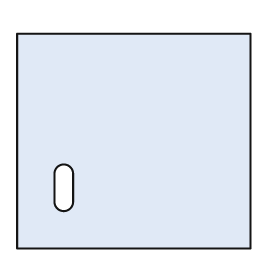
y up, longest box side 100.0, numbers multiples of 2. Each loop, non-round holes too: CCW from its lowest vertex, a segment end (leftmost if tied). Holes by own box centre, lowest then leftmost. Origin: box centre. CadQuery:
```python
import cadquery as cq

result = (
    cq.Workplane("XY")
    .moveTo(-50.0, -46.0)
    .lineTo(50.0, -46.0)
    .lineTo(50.0, 46.0)
    .lineTo(-50.0, 46.0)
    .close()
    .moveTo(-34.0, -26.0)
    .threePointArc((-30.0, -30.0), (-26.0, -26.0))
    .lineTo(-26.0, -14.0)
    .threePointArc((-30.0, -10.0), (-34.0, -14.0))
    .close()
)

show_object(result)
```